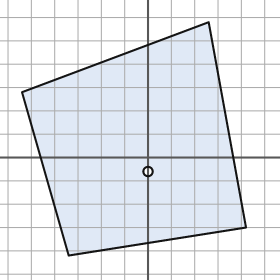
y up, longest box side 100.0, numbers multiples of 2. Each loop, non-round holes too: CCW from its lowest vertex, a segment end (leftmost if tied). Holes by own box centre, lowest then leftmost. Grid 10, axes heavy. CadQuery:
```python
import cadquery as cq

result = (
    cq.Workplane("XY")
    .moveTo(-34.0, -42.0)
    .lineTo(42.0, -30.0)
    .lineTo(26.0, 58.0)
    .lineTo(-54.0, 28.0)
    .close()
    .moveTo(0.0, -6.0)
    .circle(2.0)
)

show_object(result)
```